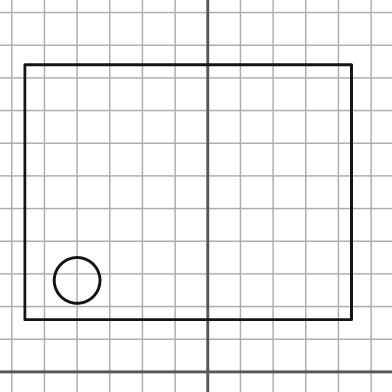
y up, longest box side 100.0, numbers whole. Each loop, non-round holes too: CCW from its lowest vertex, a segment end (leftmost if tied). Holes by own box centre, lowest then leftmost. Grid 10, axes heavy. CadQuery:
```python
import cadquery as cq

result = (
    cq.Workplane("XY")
    .moveTo(-56.0, 16.0)
    .lineTo(44.0, 16.0)
    .lineTo(44.0, 94.0)
    .lineTo(-56.0, 94.0)
    .close()
    .moveTo(-40.0, 28.0)
    .circle(7.0)
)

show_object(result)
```